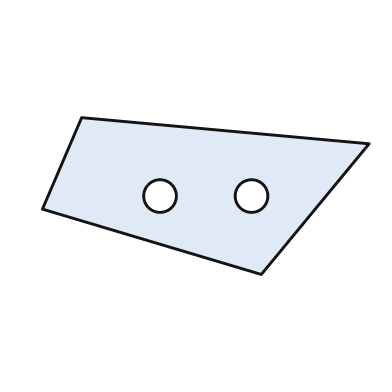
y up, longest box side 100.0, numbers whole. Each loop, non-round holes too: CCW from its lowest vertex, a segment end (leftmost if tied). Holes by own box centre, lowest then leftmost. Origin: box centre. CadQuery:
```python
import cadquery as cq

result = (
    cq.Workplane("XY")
    .moveTo(17.0, -24.0)
    .lineTo(50.0, 16.0)
    .lineTo(-38.0, 24.0)
    .lineTo(-50.0, -4.0)
    .close()
    .moveTo(-14.0, 0.0)
    .circle(5.0)
    .moveTo(14.0, 0.0)
    .circle(5.0)
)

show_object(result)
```